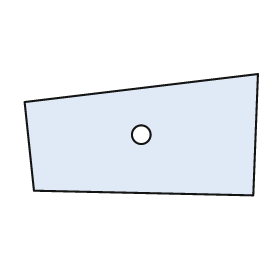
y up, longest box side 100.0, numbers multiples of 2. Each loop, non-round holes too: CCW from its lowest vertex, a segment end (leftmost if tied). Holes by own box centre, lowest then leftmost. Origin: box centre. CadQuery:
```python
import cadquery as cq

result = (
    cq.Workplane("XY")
    .moveTo(48.0, -26.0)
    .lineTo(50.0, 26.0)
    .lineTo(-50.0, 14.0)
    .lineTo(-46.0, -24.0)
    .close()
    .moveTo(0.0, 0.0)
    .circle(4.0)
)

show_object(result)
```